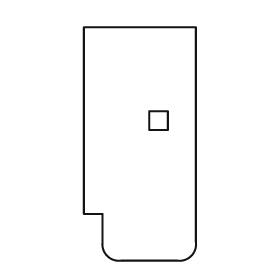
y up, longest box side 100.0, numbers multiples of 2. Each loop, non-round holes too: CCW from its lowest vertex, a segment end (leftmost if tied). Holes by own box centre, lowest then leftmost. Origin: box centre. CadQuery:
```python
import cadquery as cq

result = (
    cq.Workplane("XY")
    .moveTo(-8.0, -50.0)
    .lineTo(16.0, -50.0)
    .threePointArc((22.0, -48.0), (24.0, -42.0))
    .lineTo(24.0, 50.0)
    .lineTo(-24.0, 50.0)
    .lineTo(-24.0, -30.0)
    .lineTo(-16.0, -30.0)
    .lineTo(-16.0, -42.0)
    .threePointArc((-14.0, -48.0), (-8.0, -50.0))
    .close()
    .moveTo(4.0, 6.0)
    .lineTo(12.0, 6.0)
    .lineTo(12.0, 14.0)
    .lineTo(4.0, 14.0)
    .close()
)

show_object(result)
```